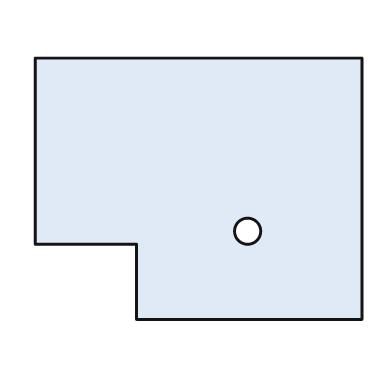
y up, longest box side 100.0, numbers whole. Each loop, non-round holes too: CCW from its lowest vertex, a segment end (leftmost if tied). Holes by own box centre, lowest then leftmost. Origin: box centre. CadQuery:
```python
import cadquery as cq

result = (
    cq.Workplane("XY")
    .moveTo(-19.0, -40.0)
    .lineTo(50.0, -40.0)
    .lineTo(50.0, 40.0)
    .lineTo(-50.0, 40.0)
    .lineTo(-50.0, -17.0)
    .lineTo(-19.0, -17.0)
    .close()
    .moveTo(15.0, -13.0)
    .circle(4.0)
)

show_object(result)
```